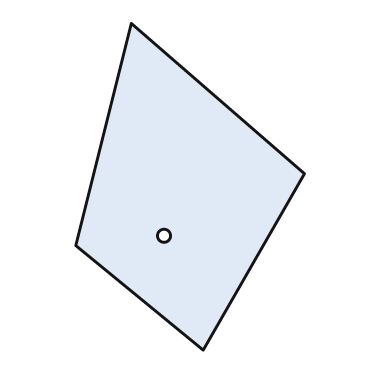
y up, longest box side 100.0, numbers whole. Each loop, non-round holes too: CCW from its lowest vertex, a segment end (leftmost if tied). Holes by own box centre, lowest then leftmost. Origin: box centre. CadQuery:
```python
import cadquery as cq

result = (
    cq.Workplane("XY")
    .moveTo(4.0, -50.0)
    .lineTo(35.0, 4.0)
    .lineTo(-18.0, 50.0)
    .lineTo(-35.0, -18.0)
    .close()
    .moveTo(-8.0, -15.0)
    .circle(2.0)
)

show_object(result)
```